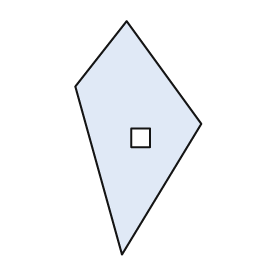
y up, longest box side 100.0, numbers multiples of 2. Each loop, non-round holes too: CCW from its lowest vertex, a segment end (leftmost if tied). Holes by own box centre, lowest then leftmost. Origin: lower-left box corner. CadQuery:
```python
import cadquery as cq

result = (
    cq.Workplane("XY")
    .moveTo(20.0, 0.0)
    .lineTo(54.0, 56.0)
    .lineTo(22.0, 100.0)
    .lineTo(0.0, 72.0)
    .close()
    .moveTo(24.0, 46.0)
    .lineTo(32.0, 46.0)
    .lineTo(32.0, 54.0)
    .lineTo(24.0, 54.0)
    .close()
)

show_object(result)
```